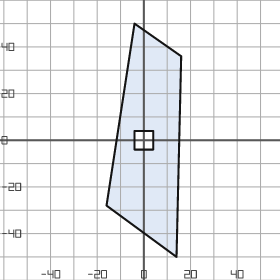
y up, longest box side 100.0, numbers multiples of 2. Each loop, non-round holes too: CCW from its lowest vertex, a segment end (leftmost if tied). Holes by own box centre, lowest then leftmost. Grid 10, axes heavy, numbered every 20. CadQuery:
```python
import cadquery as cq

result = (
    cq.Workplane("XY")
    .moveTo(14.0, -50.0)
    .lineTo(16.0, 36.0)
    .lineTo(-4.0, 50.0)
    .lineTo(-16.0, -28.0)
    .close()
    .moveTo(-4.0, -4.0)
    .lineTo(4.0, -4.0)
    .lineTo(4.0, 4.0)
    .lineTo(-4.0, 4.0)
    .close()
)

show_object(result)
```